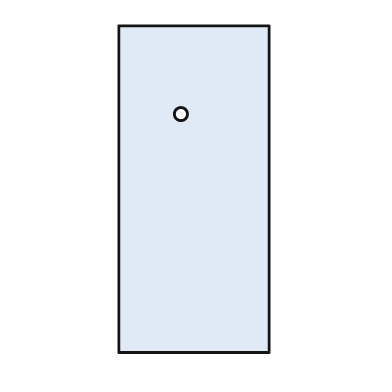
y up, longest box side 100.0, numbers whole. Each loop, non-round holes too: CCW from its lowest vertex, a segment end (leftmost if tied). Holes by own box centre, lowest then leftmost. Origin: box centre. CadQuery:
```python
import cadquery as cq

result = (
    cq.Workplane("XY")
    .moveTo(-23.0, -50.0)
    .lineTo(23.0, -50.0)
    .lineTo(23.0, 50.0)
    .lineTo(-23.0, 50.0)
    .close()
    .moveTo(-4.0, 23.0)
    .circle(2.0)
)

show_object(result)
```